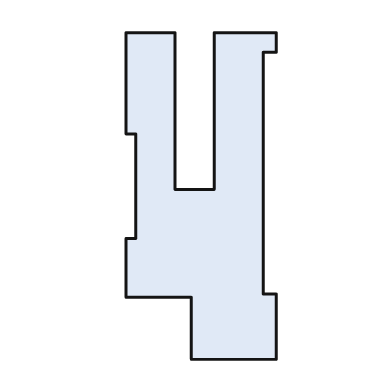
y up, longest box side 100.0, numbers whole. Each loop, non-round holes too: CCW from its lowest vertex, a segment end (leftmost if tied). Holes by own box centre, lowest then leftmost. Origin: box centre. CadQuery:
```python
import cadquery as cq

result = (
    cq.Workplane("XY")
    .moveTo(-3.0, -50.0)
    .lineTo(23.0, -50.0)
    .lineTo(23.0, -30.0)
    .lineTo(19.0, -30.0)
    .lineTo(19.0, 44.0)
    .lineTo(23.0, 44.0)
    .lineTo(23.0, 50.0)
    .lineTo(4.0, 50.0)
    .lineTo(4.0, 2.0)
    .lineTo(-8.0, 2.0)
    .lineTo(-8.0, 50.0)
    .lineTo(-23.0, 50.0)
    .lineTo(-23.0, 19.0)
    .lineTo(-20.0, 19.0)
    .lineTo(-20.0, -13.0)
    .lineTo(-23.0, -13.0)
    .lineTo(-23.0, -31.0)
    .lineTo(-3.0, -31.0)
    .close()
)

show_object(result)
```